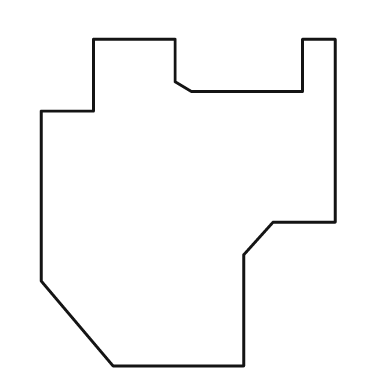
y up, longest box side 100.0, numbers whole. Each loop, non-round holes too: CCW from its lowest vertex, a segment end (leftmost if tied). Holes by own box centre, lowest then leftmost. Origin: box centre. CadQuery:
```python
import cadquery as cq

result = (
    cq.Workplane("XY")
    .moveTo(-23.0, -50.0)
    .lineTo(17.0, -50.0)
    .lineTo(17.0, -16.0)
    .lineTo(26.0, -6.0)
    .lineTo(45.0, -6.0)
    .lineTo(45.0, 50.0)
    .lineTo(35.0, 50.0)
    .lineTo(35.0, 34.0)
    .lineTo(1.0, 34.0)
    .lineTo(-4.0, 37.0)
    .lineTo(-4.0, 50.0)
    .lineTo(-29.0, 50.0)
    .lineTo(-29.0, 28.0)
    .lineTo(-45.0, 28.0)
    .lineTo(-45.0, -24.0)
    .close()
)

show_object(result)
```